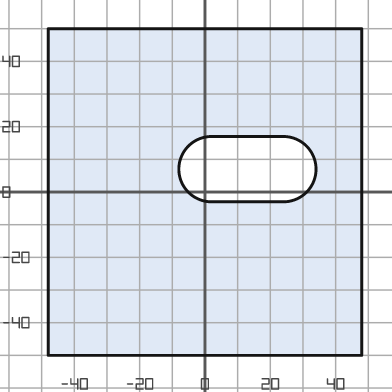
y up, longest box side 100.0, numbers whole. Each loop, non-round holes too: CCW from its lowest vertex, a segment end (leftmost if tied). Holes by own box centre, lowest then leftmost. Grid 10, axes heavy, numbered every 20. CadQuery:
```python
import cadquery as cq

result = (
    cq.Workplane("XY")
    .moveTo(-48.0, -50.0)
    .lineTo(48.0, -50.0)
    .lineTo(48.0, 50.0)
    .lineTo(-48.0, 50.0)
    .close()
    .moveTo(2.0, -3.0)
    .lineTo(24.0, -3.0)
    .threePointArc((34.0, 7.0), (24.0, 17.0))
    .lineTo(2.0, 17.0)
    .threePointArc((-8.0, 7.0), (2.0, -3.0))
    .close()
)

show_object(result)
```